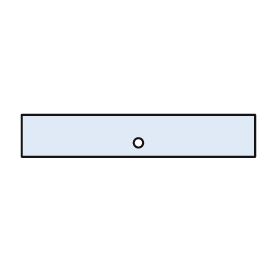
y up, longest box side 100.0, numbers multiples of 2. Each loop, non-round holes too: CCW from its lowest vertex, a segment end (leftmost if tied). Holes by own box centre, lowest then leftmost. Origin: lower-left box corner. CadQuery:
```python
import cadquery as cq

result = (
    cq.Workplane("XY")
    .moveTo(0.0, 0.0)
    .lineTo(100.0, 0.0)
    .lineTo(100.0, 18.0)
    .lineTo(0.0, 18.0)
    .close()
    .moveTo(50.0, 6.0)
    .circle(2.0)
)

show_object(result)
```